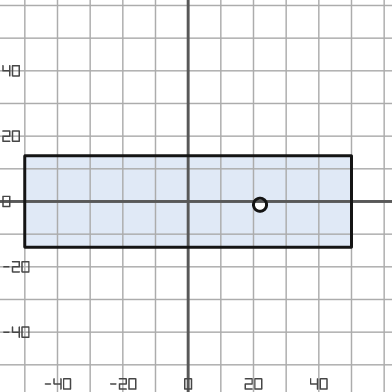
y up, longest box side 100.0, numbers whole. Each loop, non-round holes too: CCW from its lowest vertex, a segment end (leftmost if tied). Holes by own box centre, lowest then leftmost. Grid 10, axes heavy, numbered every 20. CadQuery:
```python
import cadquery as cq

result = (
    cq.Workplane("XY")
    .moveTo(-50.0, -14.0)
    .lineTo(50.0, -14.0)
    .lineTo(50.0, 14.0)
    .lineTo(-50.0, 14.0)
    .close()
    .moveTo(22.0, -1.0)
    .circle(2.0)
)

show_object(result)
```